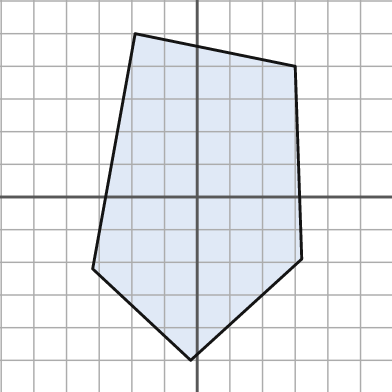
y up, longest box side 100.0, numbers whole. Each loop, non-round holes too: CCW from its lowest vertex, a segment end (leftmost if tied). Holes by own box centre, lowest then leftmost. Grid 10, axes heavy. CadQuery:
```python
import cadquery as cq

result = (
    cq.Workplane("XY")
    .moveTo(-2.0, -50.0)
    .lineTo(32.0, -19.0)
    .lineTo(30.0, 40.0)
    .lineTo(-19.0, 50.0)
    .lineTo(-32.0, -22.0)
    .close()
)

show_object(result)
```